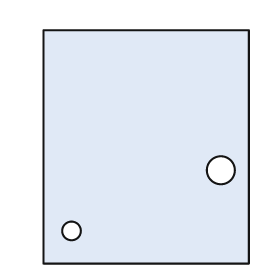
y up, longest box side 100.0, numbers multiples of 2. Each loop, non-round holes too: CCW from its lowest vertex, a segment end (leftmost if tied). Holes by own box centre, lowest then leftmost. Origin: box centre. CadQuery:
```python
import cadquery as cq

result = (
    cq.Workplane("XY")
    .moveTo(-44.0, -50.0)
    .lineTo(44.0, -50.0)
    .lineTo(44.0, 50.0)
    .lineTo(-44.0, 50.0)
    .close()
    .moveTo(-32.0, -36.0)
    .circle(4.0)
    .moveTo(32.0, -10.0)
    .circle(6.0)
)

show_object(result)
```